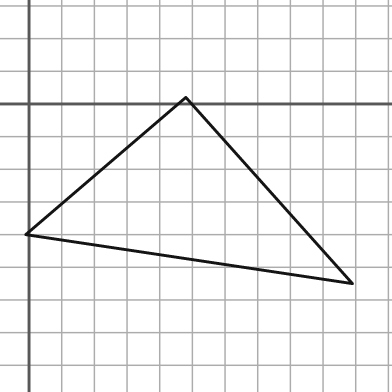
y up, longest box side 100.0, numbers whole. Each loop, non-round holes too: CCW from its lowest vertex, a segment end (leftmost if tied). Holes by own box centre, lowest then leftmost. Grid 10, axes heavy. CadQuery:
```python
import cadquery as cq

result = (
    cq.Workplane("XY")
    .moveTo(99.0, -55.0)
    .lineTo(48.0, 2.0)
    .lineTo(-1.0, -40.0)
    .close()
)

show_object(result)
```